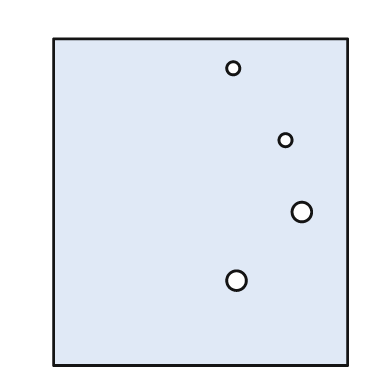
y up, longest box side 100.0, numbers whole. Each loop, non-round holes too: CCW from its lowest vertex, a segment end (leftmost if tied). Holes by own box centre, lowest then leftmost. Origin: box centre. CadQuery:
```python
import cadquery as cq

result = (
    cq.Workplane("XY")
    .moveTo(-45.0, -50.0)
    .lineTo(45.0, -50.0)
    .lineTo(45.0, 50.0)
    .lineTo(-45.0, 50.0)
    .close()
    .moveTo(11.0, -24.0)
    .circle(3.0)
    .moveTo(31.0, -3.0)
    .circle(3.0)
    .moveTo(26.0, 19.0)
    .circle(2.0)
    .moveTo(10.0, 41.0)
    .circle(2.0)
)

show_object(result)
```